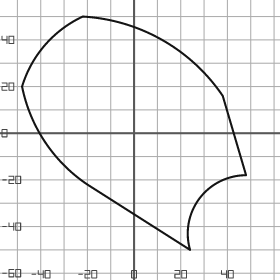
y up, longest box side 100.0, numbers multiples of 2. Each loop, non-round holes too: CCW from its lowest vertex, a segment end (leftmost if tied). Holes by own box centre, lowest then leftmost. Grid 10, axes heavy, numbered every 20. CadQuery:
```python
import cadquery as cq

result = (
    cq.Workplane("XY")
    .moveTo(24.0, -50.0)
    .threePointArc((28.0, -28.0), (48.0, -18.0))
    .lineTo(38.0, 16.0)
    .threePointArc((12.0, 40.0), (-22.0, 50.0))
    .threePointArc((-38.0, 38.0), (-48.0, 20.0))
    .threePointArc((-38.0, -4.0), (-20.0, -22.0))
    .close()
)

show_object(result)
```